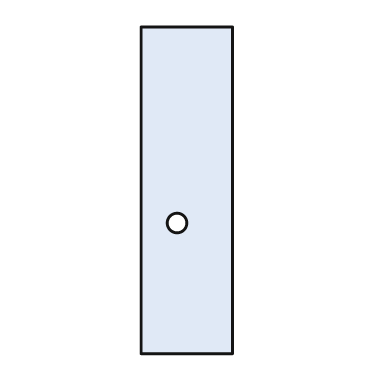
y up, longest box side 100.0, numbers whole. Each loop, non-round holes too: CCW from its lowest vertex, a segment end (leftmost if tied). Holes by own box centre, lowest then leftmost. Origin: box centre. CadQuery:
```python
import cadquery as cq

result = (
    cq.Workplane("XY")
    .moveTo(-14.0, -50.0)
    .lineTo(14.0, -50.0)
    .lineTo(14.0, 50.0)
    .lineTo(-14.0, 50.0)
    .close()
    .moveTo(-3.0, -10.0)
    .circle(3.0)
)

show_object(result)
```